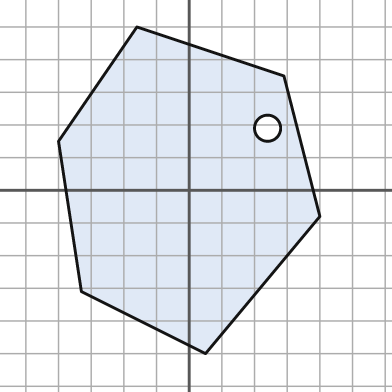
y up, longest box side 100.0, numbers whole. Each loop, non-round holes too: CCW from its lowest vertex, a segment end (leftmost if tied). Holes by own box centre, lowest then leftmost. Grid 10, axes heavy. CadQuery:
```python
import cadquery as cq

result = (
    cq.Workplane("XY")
    .moveTo(5.0, -50.0)
    .lineTo(40.0, -8.0)
    .lineTo(29.0, 35.0)
    .lineTo(-16.0, 50.0)
    .lineTo(-40.0, 15.0)
    .lineTo(-33.0, -31.0)
    .close()
    .moveTo(24.0, 19.0)
    .circle(4.0)
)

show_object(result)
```